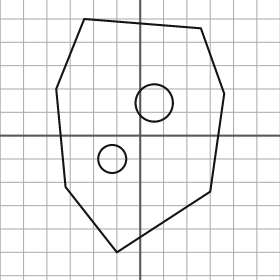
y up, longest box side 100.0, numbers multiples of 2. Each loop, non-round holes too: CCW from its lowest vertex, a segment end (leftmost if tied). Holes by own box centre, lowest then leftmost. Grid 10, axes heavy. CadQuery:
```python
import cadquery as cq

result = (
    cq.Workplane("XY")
    .moveTo(-10.0, -50.0)
    .lineTo(30.0, -24.0)
    .lineTo(36.0, 18.0)
    .lineTo(26.0, 46.0)
    .lineTo(-24.0, 50.0)
    .lineTo(-36.0, 20.0)
    .lineTo(-32.0, -22.0)
    .close()
    .moveTo(-12.0, -10.0)
    .circle(6.0)
    .moveTo(6.0, 14.0)
    .circle(8.0)
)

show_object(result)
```